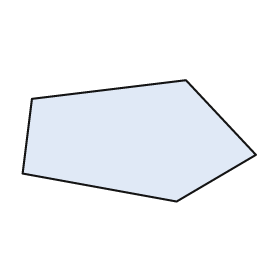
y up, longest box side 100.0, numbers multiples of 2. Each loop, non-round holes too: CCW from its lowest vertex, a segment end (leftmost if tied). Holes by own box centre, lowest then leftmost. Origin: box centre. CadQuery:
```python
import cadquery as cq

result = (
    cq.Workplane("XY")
    .moveTo(16.0, -26.0)
    .lineTo(50.0, -6.0)
    .lineTo(20.0, 26.0)
    .lineTo(-46.0, 18.0)
    .lineTo(-50.0, -14.0)
    .close()
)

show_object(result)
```